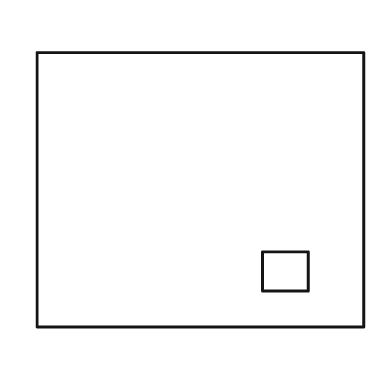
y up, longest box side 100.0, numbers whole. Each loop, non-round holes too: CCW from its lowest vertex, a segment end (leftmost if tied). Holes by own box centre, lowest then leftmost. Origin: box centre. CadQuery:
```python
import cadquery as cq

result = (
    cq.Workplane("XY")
    .moveTo(-50.0, -42.0)
    .lineTo(50.0, -42.0)
    .lineTo(50.0, 42.0)
    .lineTo(-50.0, 42.0)
    .close()
    .moveTo(19.0, -31.0)
    .lineTo(33.0, -31.0)
    .lineTo(33.0, -19.0)
    .lineTo(19.0, -19.0)
    .close()
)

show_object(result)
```